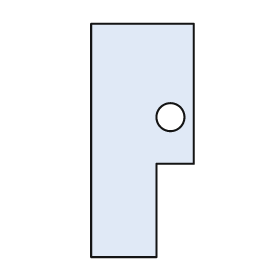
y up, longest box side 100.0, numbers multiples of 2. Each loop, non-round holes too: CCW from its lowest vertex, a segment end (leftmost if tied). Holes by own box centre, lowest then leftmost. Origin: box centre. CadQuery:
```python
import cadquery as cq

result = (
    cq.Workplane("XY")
    .moveTo(-22.0, -50.0)
    .lineTo(6.0, -50.0)
    .lineTo(6.0, -10.0)
    .lineTo(22.0, -10.0)
    .lineTo(22.0, 50.0)
    .lineTo(-22.0, 50.0)
    .close()
    .moveTo(12.0, 10.0)
    .circle(6.0)
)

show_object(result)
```